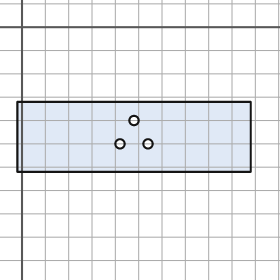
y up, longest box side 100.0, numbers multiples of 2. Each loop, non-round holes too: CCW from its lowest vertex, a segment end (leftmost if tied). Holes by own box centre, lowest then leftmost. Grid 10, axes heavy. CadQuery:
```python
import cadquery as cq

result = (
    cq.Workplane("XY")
    .moveTo(-2.0, -62.0)
    .lineTo(98.0, -62.0)
    .lineTo(98.0, -32.0)
    .lineTo(-2.0, -32.0)
    .close()
    .moveTo(42.0, -50.0)
    .circle(2.0)
    .moveTo(54.0, -50.0)
    .circle(2.0)
    .moveTo(48.0, -40.0)
    .circle(2.0)
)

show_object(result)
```